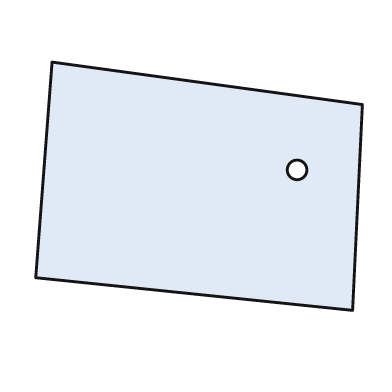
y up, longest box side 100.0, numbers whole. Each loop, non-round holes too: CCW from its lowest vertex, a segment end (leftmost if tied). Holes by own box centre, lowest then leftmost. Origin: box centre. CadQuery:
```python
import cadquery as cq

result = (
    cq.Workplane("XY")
    .moveTo(47.0, -38.0)
    .lineTo(50.0, 25.0)
    .lineTo(-45.0, 38.0)
    .lineTo(-50.0, -28.0)
    .close()
    .moveTo(30.0, 5.0)
    .circle(3.0)
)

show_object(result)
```